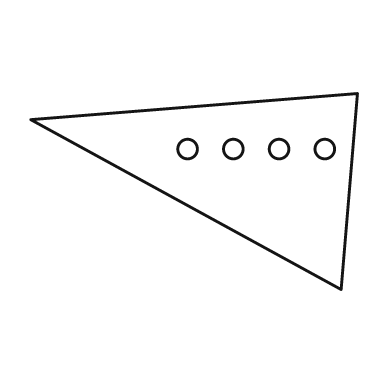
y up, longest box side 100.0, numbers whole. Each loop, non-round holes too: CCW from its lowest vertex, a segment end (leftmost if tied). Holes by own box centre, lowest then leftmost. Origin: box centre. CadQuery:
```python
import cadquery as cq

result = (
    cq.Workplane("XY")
    .moveTo(45.0, -30.0)
    .lineTo(50.0, 30.0)
    .lineTo(-50.0, 22.0)
    .close()
    .moveTo(-2.0, 13.0)
    .circle(3.0)
    .moveTo(12.0, 13.0)
    .circle(3.0)
    .moveTo(26.0, 13.0)
    .circle(3.0)
    .moveTo(40.0, 13.0)
    .circle(3.0)
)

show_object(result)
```